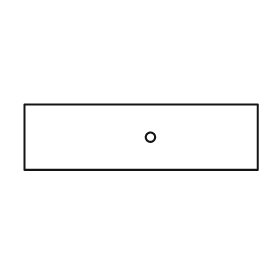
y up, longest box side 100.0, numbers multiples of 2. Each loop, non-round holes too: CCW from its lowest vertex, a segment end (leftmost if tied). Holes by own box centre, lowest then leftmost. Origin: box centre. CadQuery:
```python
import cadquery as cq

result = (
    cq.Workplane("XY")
    .moveTo(-50.0, -14.0)
    .lineTo(50.0, -14.0)
    .lineTo(50.0, 14.0)
    .lineTo(-50.0, 14.0)
    .close()
    .moveTo(4.0, 0.0)
    .circle(2.0)
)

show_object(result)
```